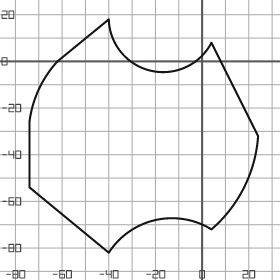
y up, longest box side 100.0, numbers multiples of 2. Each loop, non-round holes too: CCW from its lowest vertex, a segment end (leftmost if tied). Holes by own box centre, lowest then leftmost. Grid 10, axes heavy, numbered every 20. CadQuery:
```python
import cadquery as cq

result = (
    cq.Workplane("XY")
    .moveTo(-40.0, -82.0)
    .threePointArc((-20.0, -68.0), (4.0, -72.0))
    .threePointArc((18.0, -54.0), (24.0, -32.0))
    .lineTo(4.0, 8.0)
    .threePointArc((-22.0, -4.0), (-40.0, 18.0))
    .lineTo(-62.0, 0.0)
    .threePointArc((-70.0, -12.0), (-74.0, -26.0))
    .lineTo(-74.0, -54.0)
    .close()
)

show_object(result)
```